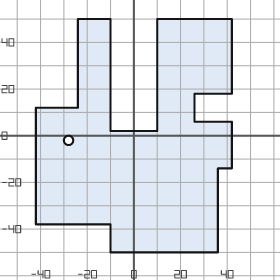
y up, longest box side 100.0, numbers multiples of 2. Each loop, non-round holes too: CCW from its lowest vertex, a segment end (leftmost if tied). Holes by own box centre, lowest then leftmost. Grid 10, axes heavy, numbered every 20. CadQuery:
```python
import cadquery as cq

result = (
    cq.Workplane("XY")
    .moveTo(-10.0, -50.0)
    .lineTo(36.0, -50.0)
    .lineTo(36.0, -14.0)
    .lineTo(42.0, -14.0)
    .lineTo(42.0, 6.0)
    .lineTo(26.0, 6.0)
    .lineTo(26.0, 18.0)
    .lineTo(42.0, 18.0)
    .lineTo(42.0, 50.0)
    .lineTo(10.0, 50.0)
    .lineTo(10.0, 2.0)
    .lineTo(-10.0, 2.0)
    .lineTo(-10.0, 50.0)
    .lineTo(-24.0, 50.0)
    .lineTo(-24.0, 12.0)
    .lineTo(-42.0, 12.0)
    .lineTo(-42.0, -38.0)
    .lineTo(-10.0, -38.0)
    .close()
    .moveTo(-28.0, -2.0)
    .circle(2.0)
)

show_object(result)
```